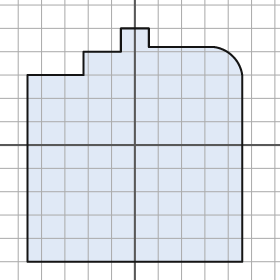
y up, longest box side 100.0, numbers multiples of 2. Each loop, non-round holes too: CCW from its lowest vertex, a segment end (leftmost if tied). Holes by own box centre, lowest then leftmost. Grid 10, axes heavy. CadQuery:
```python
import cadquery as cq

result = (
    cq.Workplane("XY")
    .moveTo(-46.0, -50.0)
    .lineTo(46.0, -50.0)
    .lineTo(46.0, 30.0)
    .threePointArc((42.0, 38.0), (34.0, 42.0))
    .lineTo(6.0, 42.0)
    .lineTo(6.0, 50.0)
    .lineTo(-6.0, 50.0)
    .lineTo(-6.0, 40.0)
    .lineTo(-22.0, 40.0)
    .lineTo(-22.0, 30.0)
    .lineTo(-46.0, 30.0)
    .close()
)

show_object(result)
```